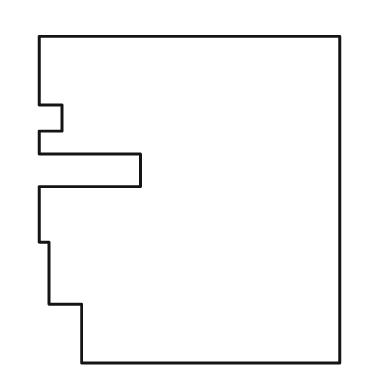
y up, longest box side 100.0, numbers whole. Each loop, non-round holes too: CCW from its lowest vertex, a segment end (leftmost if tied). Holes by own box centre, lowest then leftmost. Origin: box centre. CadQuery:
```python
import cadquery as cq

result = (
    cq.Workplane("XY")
    .moveTo(-33.0, -50.0)
    .lineTo(46.0, -50.0)
    .lineTo(46.0, 50.0)
    .lineTo(-46.0, 50.0)
    .lineTo(-46.0, 29.0)
    .lineTo(-39.0, 29.0)
    .lineTo(-39.0, 21.0)
    .lineTo(-46.0, 21.0)
    .lineTo(-46.0, 14.0)
    .lineTo(-15.0, 14.0)
    .lineTo(-15.0, 4.0)
    .lineTo(-46.0, 4.0)
    .lineTo(-46.0, -13.0)
    .lineTo(-43.0, -13.0)
    .lineTo(-43.0, -32.0)
    .lineTo(-33.0, -32.0)
    .close()
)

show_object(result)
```